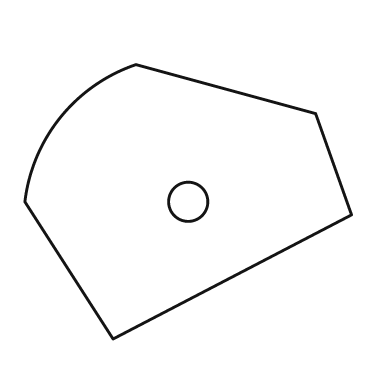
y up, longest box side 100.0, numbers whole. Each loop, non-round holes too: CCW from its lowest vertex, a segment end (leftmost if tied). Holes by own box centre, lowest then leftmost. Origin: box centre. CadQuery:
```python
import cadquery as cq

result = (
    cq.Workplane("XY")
    .moveTo(-23.0, -42.0)
    .lineTo(50.0, -4.0)
    .lineTo(39.0, 27.0)
    .lineTo(-16.0, 42.0)
    .threePointArc((-39.0, 26.0), (-50.0, 0.0))
    .close()
    .moveTo(0.0, 0.0)
    .circle(6.0)
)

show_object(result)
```